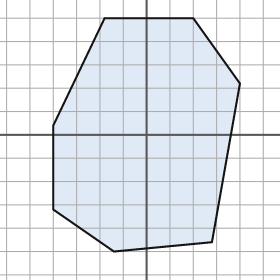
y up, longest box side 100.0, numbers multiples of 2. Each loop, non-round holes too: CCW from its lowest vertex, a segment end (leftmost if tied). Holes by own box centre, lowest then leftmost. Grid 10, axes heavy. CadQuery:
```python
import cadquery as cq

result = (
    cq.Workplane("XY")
    .moveTo(-14.0, -50.0)
    .lineTo(28.0, -46.0)
    .lineTo(40.0, 22.0)
    .lineTo(20.0, 50.0)
    .lineTo(-18.0, 50.0)
    .lineTo(-40.0, 4.0)
    .lineTo(-40.0, -32.0)
    .close()
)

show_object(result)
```